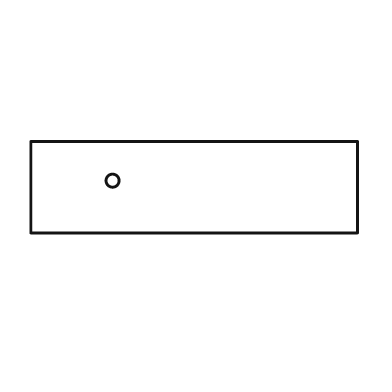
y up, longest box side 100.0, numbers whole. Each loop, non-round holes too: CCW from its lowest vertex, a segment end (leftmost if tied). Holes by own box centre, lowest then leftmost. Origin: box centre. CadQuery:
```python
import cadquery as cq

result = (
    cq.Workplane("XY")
    .moveTo(-50.0, -14.0)
    .lineTo(50.0, -14.0)
    .lineTo(50.0, 14.0)
    .lineTo(-50.0, 14.0)
    .close()
    .moveTo(-25.0, 2.0)
    .circle(2.0)
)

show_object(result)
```